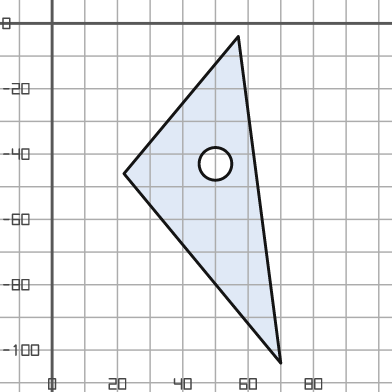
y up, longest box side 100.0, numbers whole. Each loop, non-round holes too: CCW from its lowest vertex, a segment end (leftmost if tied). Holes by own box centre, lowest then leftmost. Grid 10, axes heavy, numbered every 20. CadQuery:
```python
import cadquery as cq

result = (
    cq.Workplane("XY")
    .moveTo(70.0, -104.0)
    .lineTo(57.0, -4.0)
    .lineTo(22.0, -46.0)
    .close()
    .moveTo(50.0, -43.0)
    .circle(5.0)
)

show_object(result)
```